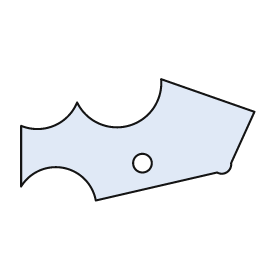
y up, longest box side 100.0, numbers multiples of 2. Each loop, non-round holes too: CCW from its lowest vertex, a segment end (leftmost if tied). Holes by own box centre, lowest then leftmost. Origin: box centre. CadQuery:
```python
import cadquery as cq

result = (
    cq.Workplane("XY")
    .moveTo(-18.0, -26.0)
    .lineTo(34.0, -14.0)
    .threePointArc((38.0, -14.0), (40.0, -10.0))
    .lineTo(50.0, 12.0)
    .lineTo(10.0, 26.0)
    .threePointArc((-4.0, 6.0), (-26.0, 16.0))
    .threePointArc((-36.0, 6.0), (-50.0, 6.0))
    .lineTo(-50.0, -20.0)
    .threePointArc((-32.0, -12.0), (-18.0, -26.0))
    .close()
    .moveTo(2.0, -10.0)
    .circle(4.0)
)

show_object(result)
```